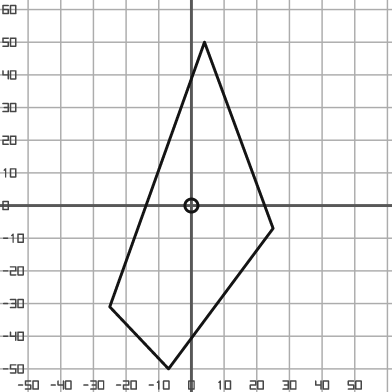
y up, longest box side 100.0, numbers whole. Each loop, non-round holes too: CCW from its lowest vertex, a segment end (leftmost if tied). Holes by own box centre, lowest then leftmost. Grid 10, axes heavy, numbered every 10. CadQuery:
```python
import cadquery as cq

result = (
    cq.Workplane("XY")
    .moveTo(-7.0, -50.0)
    .lineTo(25.0, -7.0)
    .lineTo(4.0, 50.0)
    .lineTo(-25.0, -31.0)
    .close()
    .moveTo(0.0, 0.0)
    .circle(2.0)
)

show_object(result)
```